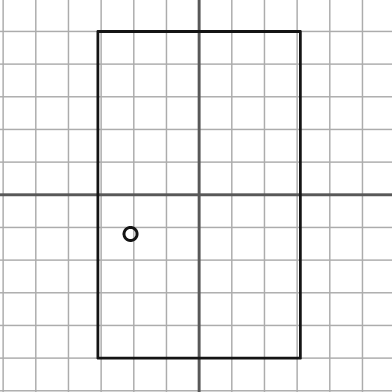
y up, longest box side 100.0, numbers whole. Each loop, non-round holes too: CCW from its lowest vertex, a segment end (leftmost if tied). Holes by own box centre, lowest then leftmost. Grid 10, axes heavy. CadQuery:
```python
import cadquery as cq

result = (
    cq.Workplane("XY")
    .moveTo(-31.0, -50.0)
    .lineTo(31.0, -50.0)
    .lineTo(31.0, 50.0)
    .lineTo(-31.0, 50.0)
    .close()
    .moveTo(-21.0, -12.0)
    .circle(2.0)
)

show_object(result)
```